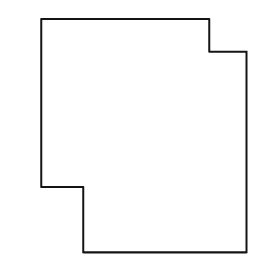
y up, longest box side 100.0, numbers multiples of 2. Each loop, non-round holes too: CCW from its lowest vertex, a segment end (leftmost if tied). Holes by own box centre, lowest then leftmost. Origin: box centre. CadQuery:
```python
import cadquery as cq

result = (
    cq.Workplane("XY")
    .moveTo(-26.0, -50.0)
    .lineTo(44.0, -50.0)
    .lineTo(44.0, 36.0)
    .lineTo(28.0, 36.0)
    .lineTo(28.0, 50.0)
    .lineTo(-44.0, 50.0)
    .lineTo(-44.0, -22.0)
    .lineTo(-26.0, -22.0)
    .close()
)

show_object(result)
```